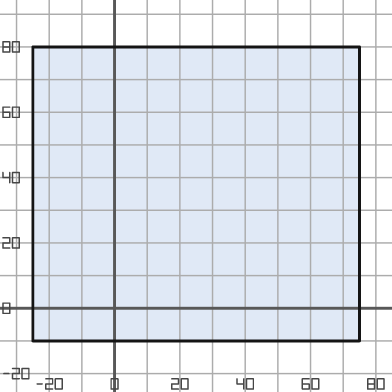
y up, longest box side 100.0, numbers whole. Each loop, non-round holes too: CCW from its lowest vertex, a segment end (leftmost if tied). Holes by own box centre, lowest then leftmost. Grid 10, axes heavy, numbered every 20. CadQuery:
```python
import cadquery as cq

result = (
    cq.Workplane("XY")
    .moveTo(-25.0, -10.0)
    .lineTo(75.0, -10.0)
    .lineTo(75.0, 80.0)
    .lineTo(-25.0, 80.0)
    .close()
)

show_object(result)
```